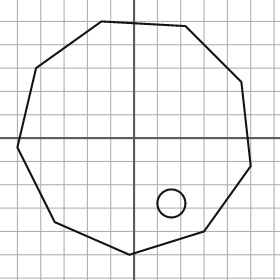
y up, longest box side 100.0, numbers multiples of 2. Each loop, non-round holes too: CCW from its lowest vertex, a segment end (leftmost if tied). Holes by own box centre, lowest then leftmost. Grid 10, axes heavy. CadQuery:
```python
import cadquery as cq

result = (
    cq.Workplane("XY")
    .moveTo(-2.0, -50.0)
    .lineTo(30.0, -40.0)
    .lineTo(50.0, -12.0)
    .lineTo(46.0, 24.0)
    .lineTo(22.0, 48.0)
    .lineTo(-14.0, 50.0)
    .lineTo(-42.0, 30.0)
    .lineTo(-50.0, -4.0)
    .lineTo(-34.0, -36.0)
    .close()
    .moveTo(16.0, -28.0)
    .circle(6.0)
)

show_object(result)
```